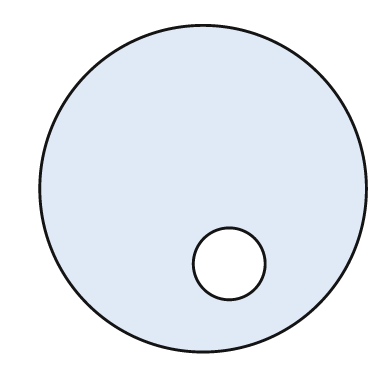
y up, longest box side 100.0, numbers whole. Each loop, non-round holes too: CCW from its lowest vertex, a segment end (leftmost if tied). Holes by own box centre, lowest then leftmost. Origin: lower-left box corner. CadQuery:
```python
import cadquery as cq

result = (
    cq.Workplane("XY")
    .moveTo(50.0, 50.0)
    .circle(50.0)
    .moveTo(58.0, 27.0)
    .circle(11.0)
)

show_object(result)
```